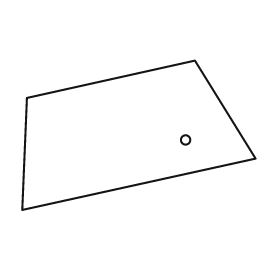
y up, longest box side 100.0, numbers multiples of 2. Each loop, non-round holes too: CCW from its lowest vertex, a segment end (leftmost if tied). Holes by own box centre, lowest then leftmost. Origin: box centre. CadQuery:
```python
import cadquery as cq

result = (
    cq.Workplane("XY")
    .moveTo(-50.0, -32.0)
    .lineTo(50.0, -10.0)
    .lineTo(24.0, 32.0)
    .lineTo(-48.0, 16.0)
    .close()
    .moveTo(20.0, -2.0)
    .circle(2.0)
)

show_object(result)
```